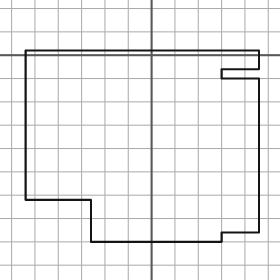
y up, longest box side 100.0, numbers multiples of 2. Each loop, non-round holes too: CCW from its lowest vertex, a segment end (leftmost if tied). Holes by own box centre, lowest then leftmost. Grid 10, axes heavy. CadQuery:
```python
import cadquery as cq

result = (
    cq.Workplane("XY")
    .moveTo(-26.0, -80.0)
    .lineTo(30.0, -80.0)
    .lineTo(30.0, -76.0)
    .lineTo(46.0, -76.0)
    .lineTo(46.0, -10.0)
    .lineTo(30.0, -10.0)
    .lineTo(30.0, -6.0)
    .lineTo(46.0, -6.0)
    .lineTo(46.0, 2.0)
    .lineTo(-54.0, 2.0)
    .lineTo(-54.0, -62.0)
    .lineTo(-26.0, -62.0)
    .close()
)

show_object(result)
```